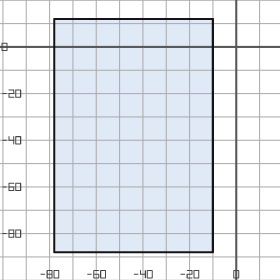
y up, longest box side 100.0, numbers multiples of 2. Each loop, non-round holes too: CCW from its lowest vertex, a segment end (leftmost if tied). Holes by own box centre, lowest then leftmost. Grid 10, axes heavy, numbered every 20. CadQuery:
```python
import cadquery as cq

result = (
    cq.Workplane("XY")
    .moveTo(-78.0, -88.0)
    .lineTo(-10.0, -88.0)
    .lineTo(-10.0, 12.0)
    .lineTo(-78.0, 12.0)
    .close()
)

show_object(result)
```